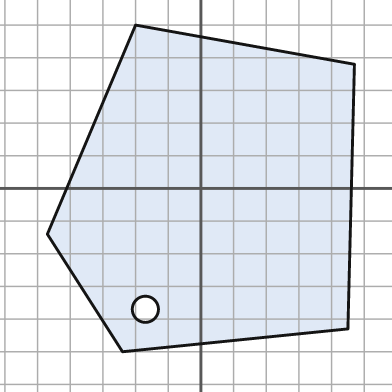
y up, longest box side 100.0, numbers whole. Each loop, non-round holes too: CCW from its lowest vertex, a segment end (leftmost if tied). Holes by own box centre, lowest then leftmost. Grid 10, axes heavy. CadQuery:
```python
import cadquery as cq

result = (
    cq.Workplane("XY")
    .moveTo(-24.0, -50.0)
    .lineTo(45.0, -43.0)
    .lineTo(47.0, 38.0)
    .lineTo(-20.0, 50.0)
    .lineTo(-47.0, -14.0)
    .close()
    .moveTo(-17.0, -37.0)
    .circle(4.0)
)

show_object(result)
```